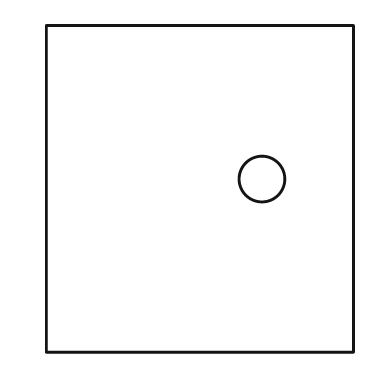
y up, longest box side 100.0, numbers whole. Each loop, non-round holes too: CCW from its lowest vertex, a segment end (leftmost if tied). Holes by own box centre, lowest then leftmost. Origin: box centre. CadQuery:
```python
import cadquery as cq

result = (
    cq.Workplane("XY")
    .moveTo(-47.0, -50.0)
    .lineTo(47.0, -50.0)
    .lineTo(47.0, 50.0)
    .lineTo(-47.0, 50.0)
    .close()
    .moveTo(19.0, 3.0)
    .circle(7.0)
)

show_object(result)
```